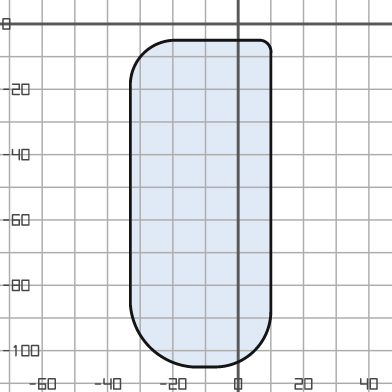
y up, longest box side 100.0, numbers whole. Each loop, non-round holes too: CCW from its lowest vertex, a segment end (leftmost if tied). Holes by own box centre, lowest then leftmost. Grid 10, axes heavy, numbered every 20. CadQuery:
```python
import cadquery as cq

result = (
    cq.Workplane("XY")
    .moveTo(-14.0, -105.0)
    .lineTo(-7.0, -105.0)
    .threePointArc((5.0, -100.0), (10.0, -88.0))
    .lineTo(10.0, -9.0)
    .threePointArc((9.0, -6.0), (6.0, -5.0))
    .lineTo(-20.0, -5.0)
    .threePointArc((-29.0, -9.0), (-33.0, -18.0))
    .lineTo(-33.0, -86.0)
    .threePointArc((-27.0, -99.0), (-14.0, -105.0))
    .close()
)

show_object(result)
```